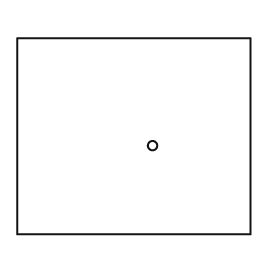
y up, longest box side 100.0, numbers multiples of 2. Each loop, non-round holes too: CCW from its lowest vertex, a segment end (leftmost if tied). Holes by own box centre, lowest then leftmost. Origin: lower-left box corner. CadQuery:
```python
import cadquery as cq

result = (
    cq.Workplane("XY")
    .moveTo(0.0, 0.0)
    .lineTo(100.0, 0.0)
    .lineTo(100.0, 84.0)
    .lineTo(0.0, 84.0)
    .close()
    .moveTo(58.0, 38.0)
    .circle(2.0)
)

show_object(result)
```